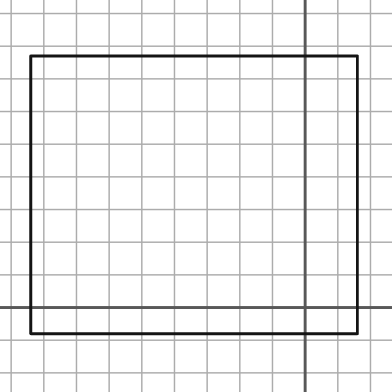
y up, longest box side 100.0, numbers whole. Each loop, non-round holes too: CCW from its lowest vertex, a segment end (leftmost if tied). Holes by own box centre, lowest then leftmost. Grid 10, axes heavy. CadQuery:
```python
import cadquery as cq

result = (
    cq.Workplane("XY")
    .moveTo(-84.0, -8.0)
    .lineTo(16.0, -8.0)
    .lineTo(16.0, 77.0)
    .lineTo(-84.0, 77.0)
    .close()
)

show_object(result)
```